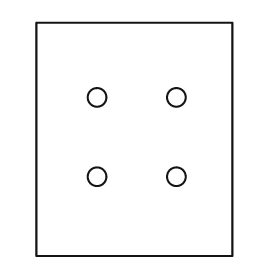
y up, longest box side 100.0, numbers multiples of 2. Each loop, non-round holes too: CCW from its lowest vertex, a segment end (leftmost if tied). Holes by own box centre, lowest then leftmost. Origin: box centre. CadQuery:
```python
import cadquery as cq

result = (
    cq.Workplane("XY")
    .moveTo(-42.0, -50.0)
    .lineTo(42.0, -50.0)
    .lineTo(42.0, 50.0)
    .lineTo(-42.0, 50.0)
    .close()
    .moveTo(-16.0, -16.0)
    .circle(4.0)
    .moveTo(18.0, -16.0)
    .circle(4.0)
    .moveTo(-16.0, 18.0)
    .circle(4.0)
    .moveTo(18.0, 18.0)
    .circle(4.0)
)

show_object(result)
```